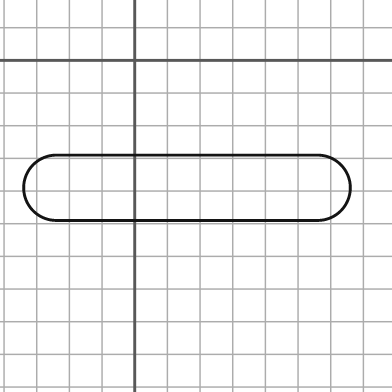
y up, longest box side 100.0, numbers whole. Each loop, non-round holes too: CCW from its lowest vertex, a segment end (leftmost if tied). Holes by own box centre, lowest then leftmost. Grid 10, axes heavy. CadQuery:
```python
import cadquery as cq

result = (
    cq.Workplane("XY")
    .moveTo(-24.0, -49.0)
    .lineTo(56.0, -49.0)
    .threePointArc((66.0, -39.0), (56.0, -29.0))
    .lineTo(-24.0, -29.0)
    .threePointArc((-34.0, -39.0), (-24.0, -49.0))
    .close()
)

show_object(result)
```